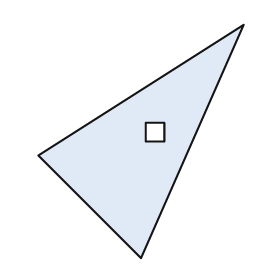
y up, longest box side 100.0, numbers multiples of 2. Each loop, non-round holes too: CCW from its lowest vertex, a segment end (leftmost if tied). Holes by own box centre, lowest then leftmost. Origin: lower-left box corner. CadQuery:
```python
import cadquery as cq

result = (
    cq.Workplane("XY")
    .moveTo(44.0, 0.0)
    .lineTo(88.0, 100.0)
    .lineTo(0.0, 44.0)
    .close()
    .moveTo(46.0, 50.0)
    .lineTo(54.0, 50.0)
    .lineTo(54.0, 58.0)
    .lineTo(46.0, 58.0)
    .close()
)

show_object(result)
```